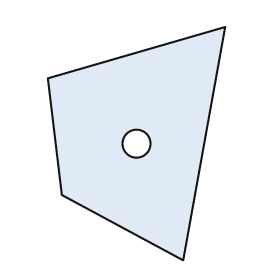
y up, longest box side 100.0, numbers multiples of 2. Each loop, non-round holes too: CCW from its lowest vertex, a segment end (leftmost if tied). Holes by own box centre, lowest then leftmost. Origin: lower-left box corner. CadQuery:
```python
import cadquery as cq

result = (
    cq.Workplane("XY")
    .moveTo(58.0, 0.0)
    .lineTo(76.0, 100.0)
    .lineTo(0.0, 78.0)
    .lineTo(6.0, 28.0)
    .close()
    .moveTo(38.0, 50.0)
    .circle(6.0)
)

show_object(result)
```